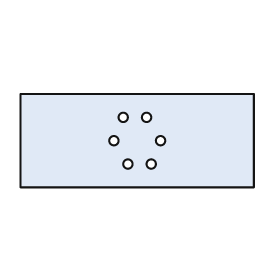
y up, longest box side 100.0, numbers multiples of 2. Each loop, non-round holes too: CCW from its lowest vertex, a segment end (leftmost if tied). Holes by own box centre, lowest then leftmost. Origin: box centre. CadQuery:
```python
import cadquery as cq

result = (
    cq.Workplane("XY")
    .moveTo(-50.0, -20.0)
    .lineTo(50.0, -20.0)
    .lineTo(50.0, 20.0)
    .lineTo(-50.0, 20.0)
    .close()
    .moveTo(-4.0, -10.0)
    .circle(2.0)
    .moveTo(6.0, -10.0)
    .circle(2.0)
    .moveTo(-10.0, 0.0)
    .circle(2.0)
    .moveTo(10.0, 0.0)
    .circle(2.0)
    .moveTo(-6.0, 10.0)
    .circle(2.0)
    .moveTo(4.0, 10.0)
    .circle(2.0)
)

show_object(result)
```